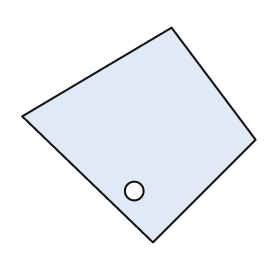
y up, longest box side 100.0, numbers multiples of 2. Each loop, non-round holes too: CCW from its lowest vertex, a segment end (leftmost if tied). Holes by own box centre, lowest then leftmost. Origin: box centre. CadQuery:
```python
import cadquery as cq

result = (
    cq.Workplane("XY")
    .moveTo(6.0, -46.0)
    .lineTo(50.0, -2.0)
    .lineTo(14.0, 46.0)
    .lineTo(-50.0, 8.0)
    .close()
    .moveTo(-2.0, -24.0)
    .circle(4.0)
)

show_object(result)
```